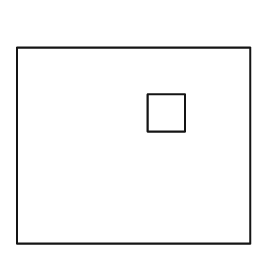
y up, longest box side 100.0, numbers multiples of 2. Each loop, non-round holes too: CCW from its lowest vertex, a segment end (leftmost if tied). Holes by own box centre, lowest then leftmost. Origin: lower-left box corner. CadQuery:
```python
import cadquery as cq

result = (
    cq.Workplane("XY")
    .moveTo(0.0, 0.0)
    .lineTo(100.0, 0.0)
    .lineTo(100.0, 84.0)
    .lineTo(0.0, 84.0)
    .close()
    .moveTo(56.0, 48.0)
    .lineTo(72.0, 48.0)
    .lineTo(72.0, 64.0)
    .lineTo(56.0, 64.0)
    .close()
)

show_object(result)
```